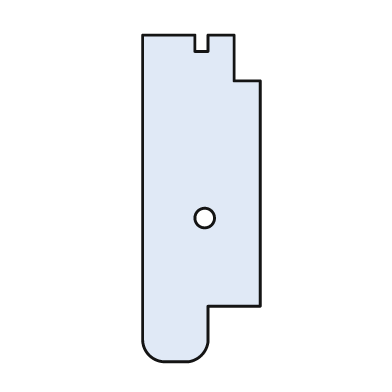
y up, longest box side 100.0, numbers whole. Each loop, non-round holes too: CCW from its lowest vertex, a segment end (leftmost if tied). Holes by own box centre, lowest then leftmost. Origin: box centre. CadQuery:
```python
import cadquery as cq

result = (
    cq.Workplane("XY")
    .moveTo(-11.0, -50.0)
    .lineTo(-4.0, -50.0)
    .threePointArc((0.0, -48.0), (2.0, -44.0))
    .lineTo(2.0, -33.0)
    .lineTo(18.0, -33.0)
    .lineTo(18.0, 36.0)
    .lineTo(10.0, 36.0)
    .lineTo(10.0, 50.0)
    .lineTo(2.0, 50.0)
    .lineTo(2.0, 45.0)
    .lineTo(-2.0, 45.0)
    .lineTo(-2.0, 50.0)
    .lineTo(-18.0, 50.0)
    .lineTo(-18.0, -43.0)
    .threePointArc((-16.0, -48.0), (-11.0, -50.0))
    .close()
    .moveTo(1.0, -6.0)
    .circle(3.0)
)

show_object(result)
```